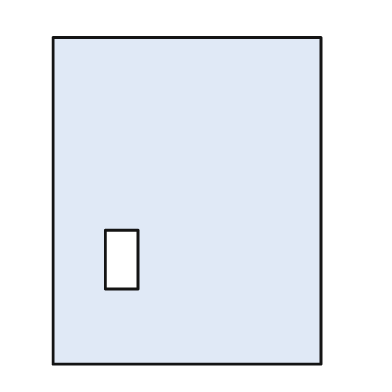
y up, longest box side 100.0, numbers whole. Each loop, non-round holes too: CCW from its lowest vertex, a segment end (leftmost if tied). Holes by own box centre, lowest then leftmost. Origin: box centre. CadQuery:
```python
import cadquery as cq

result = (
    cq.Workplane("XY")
    .moveTo(-41.0, -50.0)
    .lineTo(41.0, -50.0)
    .lineTo(41.0, 50.0)
    .lineTo(-41.0, 50.0)
    .close()
    .moveTo(-25.0, -27.0)
    .lineTo(-15.0, -27.0)
    .lineTo(-15.0, -9.0)
    .lineTo(-25.0, -9.0)
    .close()
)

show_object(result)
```